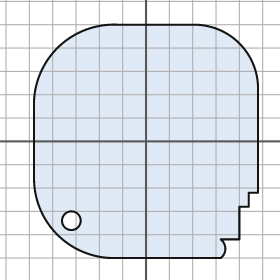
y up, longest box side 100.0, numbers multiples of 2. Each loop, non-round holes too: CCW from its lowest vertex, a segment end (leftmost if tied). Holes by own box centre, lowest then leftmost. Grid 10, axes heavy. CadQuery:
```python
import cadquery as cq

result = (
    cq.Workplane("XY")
    .moveTo(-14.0, -50.0)
    .lineTo(32.0, -50.0)
    .threePointArc((34.0, -46.0), (32.0, -42.0))
    .lineTo(40.0, -42.0)
    .lineTo(40.0, -28.0)
    .lineTo(44.0, -28.0)
    .lineTo(44.0, -22.0)
    .lineTo(48.0, -22.0)
    .lineTo(48.0, 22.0)
    .threePointArc((40.0, 42.0), (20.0, 50.0))
    .lineTo(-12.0, 50.0)
    .threePointArc((-38.0, 40.0), (-48.0, 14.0))
    .lineTo(-48.0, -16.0)
    .threePointArc((-38.0, -40.0), (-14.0, -50.0))
    .close()
    .moveTo(-32.0, -34.0)
    .circle(4.0)
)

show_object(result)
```